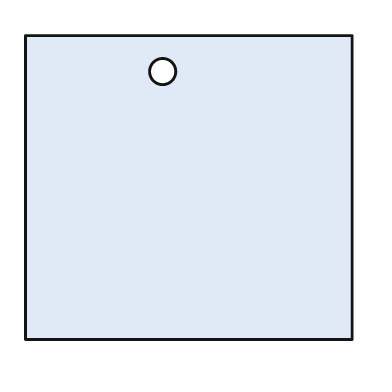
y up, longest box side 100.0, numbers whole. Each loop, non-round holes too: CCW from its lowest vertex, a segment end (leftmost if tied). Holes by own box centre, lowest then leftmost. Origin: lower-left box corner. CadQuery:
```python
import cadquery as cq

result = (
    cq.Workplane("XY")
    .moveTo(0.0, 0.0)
    .lineTo(100.0, 0.0)
    .lineTo(100.0, 93.0)
    .lineTo(0.0, 93.0)
    .close()
    .moveTo(42.0, 82.0)
    .circle(4.0)
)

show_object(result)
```